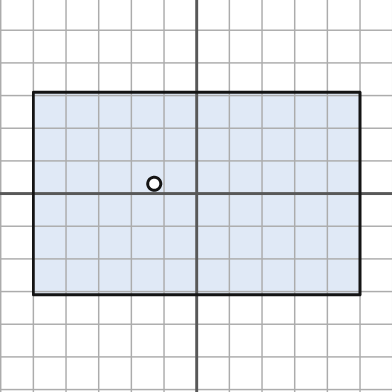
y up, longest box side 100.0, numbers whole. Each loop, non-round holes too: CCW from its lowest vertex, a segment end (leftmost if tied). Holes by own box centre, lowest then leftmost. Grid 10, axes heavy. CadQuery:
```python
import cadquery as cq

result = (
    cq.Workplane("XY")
    .moveTo(-50.0, -31.0)
    .lineTo(50.0, -31.0)
    .lineTo(50.0, 31.0)
    .lineTo(-50.0, 31.0)
    .close()
    .moveTo(-13.0, 3.0)
    .circle(2.0)
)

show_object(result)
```